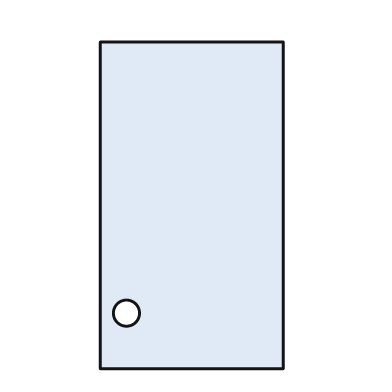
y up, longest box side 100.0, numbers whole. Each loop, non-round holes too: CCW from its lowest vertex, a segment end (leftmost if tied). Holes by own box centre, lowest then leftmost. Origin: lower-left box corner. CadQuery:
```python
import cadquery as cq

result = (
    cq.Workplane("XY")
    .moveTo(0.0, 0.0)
    .lineTo(56.0, 0.0)
    .lineTo(56.0, 100.0)
    .lineTo(0.0, 100.0)
    .close()
    .moveTo(8.0, 17.0)
    .circle(4.0)
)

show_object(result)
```